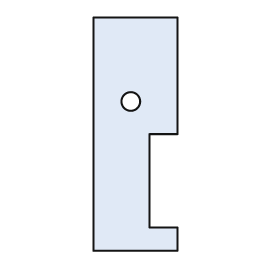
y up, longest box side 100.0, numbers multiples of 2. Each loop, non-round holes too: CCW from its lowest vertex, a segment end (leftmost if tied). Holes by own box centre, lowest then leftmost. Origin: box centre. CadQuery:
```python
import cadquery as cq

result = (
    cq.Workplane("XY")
    .moveTo(-18.0, -50.0)
    .lineTo(18.0, -50.0)
    .lineTo(18.0, -40.0)
    .lineTo(6.0, -40.0)
    .lineTo(6.0, 0.0)
    .lineTo(18.0, 0.0)
    .lineTo(18.0, 50.0)
    .lineTo(-18.0, 50.0)
    .close()
    .moveTo(-2.0, 14.0)
    .circle(4.0)
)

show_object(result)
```